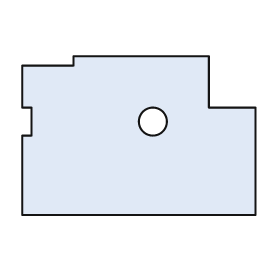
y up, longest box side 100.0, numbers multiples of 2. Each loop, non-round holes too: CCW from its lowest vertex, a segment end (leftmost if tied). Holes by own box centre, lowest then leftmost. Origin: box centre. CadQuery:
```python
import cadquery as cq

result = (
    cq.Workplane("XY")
    .moveTo(-50.0, -34.0)
    .lineTo(50.0, -34.0)
    .lineTo(50.0, 12.0)
    .lineTo(30.0, 12.0)
    .lineTo(30.0, 34.0)
    .lineTo(-28.0, 34.0)
    .lineTo(-28.0, 30.0)
    .lineTo(-50.0, 30.0)
    .lineTo(-50.0, 12.0)
    .lineTo(-46.0, 12.0)
    .lineTo(-46.0, 0.0)
    .lineTo(-50.0, 0.0)
    .close()
    .moveTo(6.0, 6.0)
    .circle(6.0)
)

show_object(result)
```